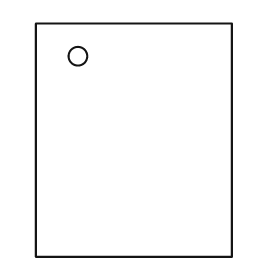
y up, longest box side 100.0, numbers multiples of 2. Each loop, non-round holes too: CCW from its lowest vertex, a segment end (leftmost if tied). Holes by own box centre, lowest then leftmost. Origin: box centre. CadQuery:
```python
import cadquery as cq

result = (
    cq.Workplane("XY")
    .moveTo(-42.0, -50.0)
    .lineTo(42.0, -50.0)
    .lineTo(42.0, 50.0)
    .lineTo(-42.0, 50.0)
    .close()
    .moveTo(-24.0, 36.0)
    .circle(4.0)
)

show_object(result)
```